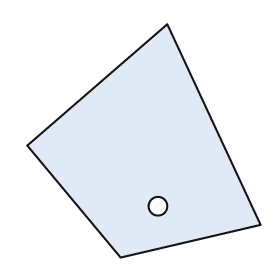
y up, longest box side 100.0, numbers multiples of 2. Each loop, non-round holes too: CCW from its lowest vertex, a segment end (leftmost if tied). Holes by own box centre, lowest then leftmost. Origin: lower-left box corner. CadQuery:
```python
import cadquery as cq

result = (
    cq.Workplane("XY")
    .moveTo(40.0, 0.0)
    .lineTo(100.0, 14.0)
    .lineTo(60.0, 100.0)
    .lineTo(0.0, 48.0)
    .close()
    .moveTo(56.0, 22.0)
    .circle(4.0)
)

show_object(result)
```